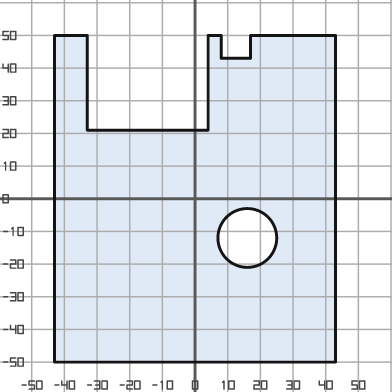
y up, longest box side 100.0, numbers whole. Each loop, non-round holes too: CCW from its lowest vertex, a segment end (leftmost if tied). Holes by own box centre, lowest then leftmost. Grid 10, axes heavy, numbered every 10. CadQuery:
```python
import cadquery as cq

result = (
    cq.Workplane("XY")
    .moveTo(-43.0, -50.0)
    .lineTo(43.0, -50.0)
    .lineTo(43.0, 50.0)
    .lineTo(17.0, 50.0)
    .lineTo(17.0, 43.0)
    .lineTo(8.0, 43.0)
    .lineTo(8.0, 50.0)
    .lineTo(4.0, 50.0)
    .lineTo(4.0, 21.0)
    .lineTo(-33.0, 21.0)
    .lineTo(-33.0, 50.0)
    .lineTo(-43.0, 50.0)
    .close()
    .moveTo(16.0, -12.0)
    .circle(9.0)
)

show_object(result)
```